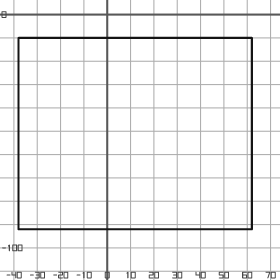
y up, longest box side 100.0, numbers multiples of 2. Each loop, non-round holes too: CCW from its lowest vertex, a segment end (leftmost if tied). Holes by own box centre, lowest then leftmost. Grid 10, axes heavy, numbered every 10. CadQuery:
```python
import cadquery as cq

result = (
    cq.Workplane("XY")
    .moveTo(-38.0, -92.0)
    .lineTo(62.0, -92.0)
    .lineTo(62.0, -10.0)
    .lineTo(-38.0, -10.0)
    .close()
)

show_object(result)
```